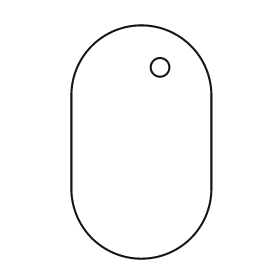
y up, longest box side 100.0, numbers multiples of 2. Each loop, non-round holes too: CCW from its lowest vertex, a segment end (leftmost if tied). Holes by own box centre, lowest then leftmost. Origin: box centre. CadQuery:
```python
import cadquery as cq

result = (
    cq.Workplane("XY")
    .moveTo(-30.0, -20.0)
    .threePointArc((0.0, -50.0), (30.0, -20.0))
    .lineTo(30.0, 20.0)
    .threePointArc((0.0, 50.0), (-30.0, 20.0))
    .close()
    .moveTo(8.0, 32.0)
    .circle(4.0)
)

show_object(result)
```